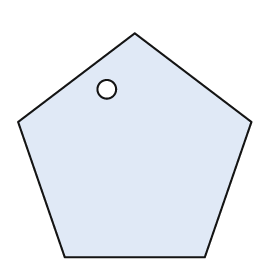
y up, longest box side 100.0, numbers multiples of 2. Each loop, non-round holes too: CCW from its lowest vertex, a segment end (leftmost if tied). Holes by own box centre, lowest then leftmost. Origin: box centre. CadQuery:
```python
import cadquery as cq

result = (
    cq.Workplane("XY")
    .moveTo(-30.0, -48.0)
    .lineTo(30.0, -48.0)
    .lineTo(50.0, 10.0)
    .lineTo(0.0, 48.0)
    .lineTo(-50.0, 10.0)
    .close()
    .moveTo(-12.0, 24.0)
    .circle(4.0)
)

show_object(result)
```